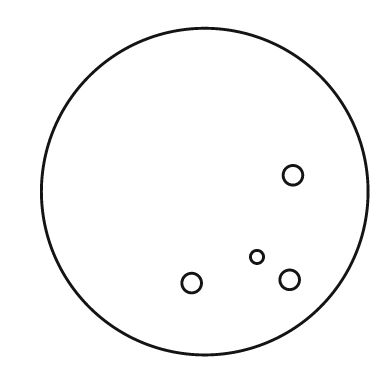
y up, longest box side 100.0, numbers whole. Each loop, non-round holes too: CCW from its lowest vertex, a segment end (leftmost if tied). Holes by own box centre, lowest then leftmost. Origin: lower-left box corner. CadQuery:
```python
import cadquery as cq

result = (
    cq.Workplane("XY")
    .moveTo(50.0, 50.0)
    .circle(50.0)
    .moveTo(46.0, 22.0)
    .circle(3.0)
    .moveTo(76.0, 23.0)
    .circle(3.0)
    .moveTo(66.0, 30.0)
    .circle(2.0)
    .moveTo(77.0, 55.0)
    .circle(3.0)
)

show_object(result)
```